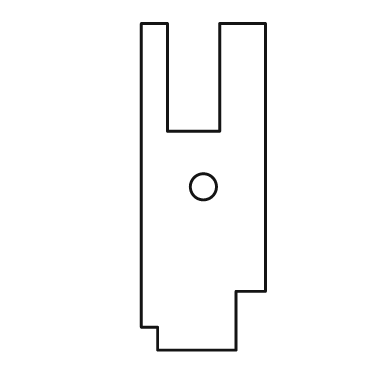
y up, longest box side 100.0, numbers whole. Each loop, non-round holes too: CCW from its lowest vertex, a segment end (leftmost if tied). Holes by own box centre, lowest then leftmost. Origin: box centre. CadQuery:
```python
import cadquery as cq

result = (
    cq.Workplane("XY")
    .moveTo(-14.0, -50.0)
    .lineTo(10.0, -50.0)
    .lineTo(10.0, -32.0)
    .lineTo(19.0, -32.0)
    .lineTo(19.0, 50.0)
    .lineTo(5.0, 50.0)
    .lineTo(5.0, 17.0)
    .lineTo(-11.0, 17.0)
    .lineTo(-11.0, 50.0)
    .lineTo(-19.0, 50.0)
    .lineTo(-19.0, -43.0)
    .lineTo(-14.0, -43.0)
    .close()
    .moveTo(0.0, 0.0)
    .circle(4.0)
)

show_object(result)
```